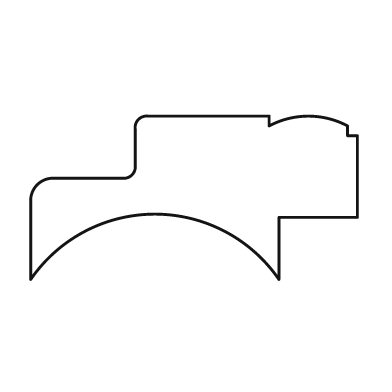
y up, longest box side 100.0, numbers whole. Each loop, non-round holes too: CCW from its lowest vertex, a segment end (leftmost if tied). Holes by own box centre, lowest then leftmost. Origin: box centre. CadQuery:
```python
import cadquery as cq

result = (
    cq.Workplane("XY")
    .moveTo(-50.0, -25.0)
    .threePointArc((-12.0, -5.0), (26.0, -25.0))
    .lineTo(26.0, -6.0)
    .lineTo(50.0, -6.0)
    .lineTo(50.0, 19.0)
    .lineTo(47.0, 19.0)
    .lineTo(47.0, 22.0)
    .threePointArc((35.0, 25.0), (23.0, 22.0))
    .lineTo(23.0, 25.0)
    .lineTo(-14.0, 25.0)
    .threePointArc((-17.0, 24.0), (-18.0, 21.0))
    .lineTo(-18.0, 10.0)
    .threePointArc((-19.0, 7.0), (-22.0, 6.0))
    .lineTo(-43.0, 6.0)
    .threePointArc((-48.0, 4.0), (-50.0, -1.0))
    .close()
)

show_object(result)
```